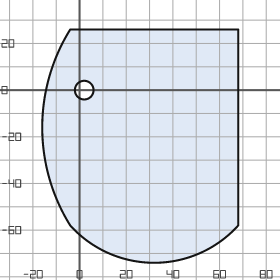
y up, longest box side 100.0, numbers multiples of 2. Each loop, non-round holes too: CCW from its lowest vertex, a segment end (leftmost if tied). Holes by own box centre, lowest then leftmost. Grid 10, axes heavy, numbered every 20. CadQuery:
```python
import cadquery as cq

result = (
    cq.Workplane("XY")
    .moveTo(-4.0, -58.0)
    .threePointArc((32.0, -74.0), (68.0, -58.0))
    .lineTo(68.0, 26.0)
    .lineTo(-4.0, 26.0)
    .threePointArc((-16.0, -16.0), (-4.0, -58.0))
    .close()
    .moveTo(2.0, 0.0)
    .circle(4.0)
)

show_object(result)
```